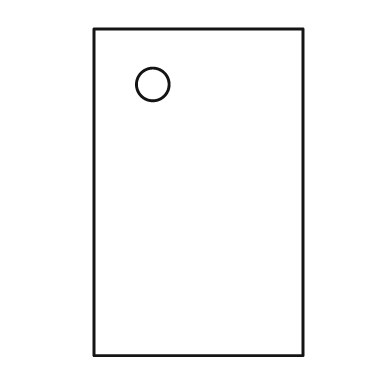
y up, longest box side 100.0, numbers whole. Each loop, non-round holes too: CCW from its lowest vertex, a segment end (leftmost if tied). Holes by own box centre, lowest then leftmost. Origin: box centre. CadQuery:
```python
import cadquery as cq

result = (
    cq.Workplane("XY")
    .moveTo(-32.0, -50.0)
    .lineTo(32.0, -50.0)
    .lineTo(32.0, 50.0)
    .lineTo(-32.0, 50.0)
    .close()
    .moveTo(-14.0, 33.0)
    .circle(5.0)
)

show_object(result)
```